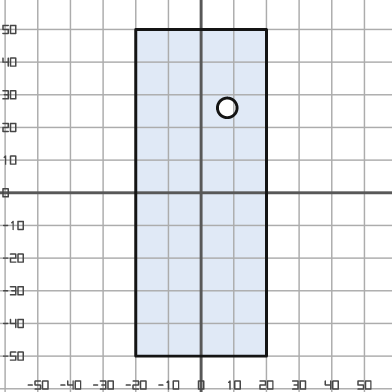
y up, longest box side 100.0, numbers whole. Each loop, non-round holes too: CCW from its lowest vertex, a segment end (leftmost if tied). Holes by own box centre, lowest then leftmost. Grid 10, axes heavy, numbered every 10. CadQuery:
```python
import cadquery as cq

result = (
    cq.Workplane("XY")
    .moveTo(-20.0, -50.0)
    .lineTo(20.0, -50.0)
    .lineTo(20.0, 50.0)
    .lineTo(-20.0, 50.0)
    .close()
    .moveTo(8.0, 26.0)
    .circle(3.0)
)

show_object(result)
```